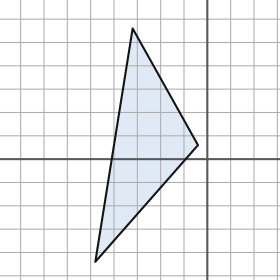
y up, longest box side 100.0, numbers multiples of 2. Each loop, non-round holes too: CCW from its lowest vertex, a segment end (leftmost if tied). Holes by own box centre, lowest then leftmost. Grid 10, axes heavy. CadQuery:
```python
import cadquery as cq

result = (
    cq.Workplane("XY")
    .moveTo(-48.0, -44.0)
    .lineTo(-4.0, 6.0)
    .lineTo(-32.0, 56.0)
    .close()
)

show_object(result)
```